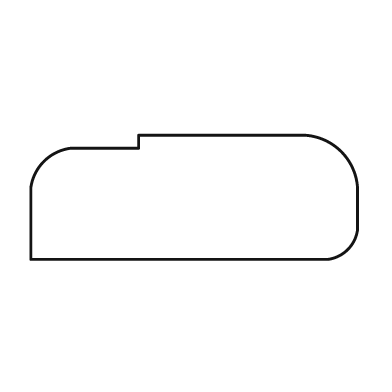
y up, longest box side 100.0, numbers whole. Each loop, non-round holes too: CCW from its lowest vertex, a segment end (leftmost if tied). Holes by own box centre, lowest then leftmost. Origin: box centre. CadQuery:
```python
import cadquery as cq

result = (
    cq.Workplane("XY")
    .moveTo(-50.0, -19.0)
    .lineTo(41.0, -19.0)
    .threePointArc((47.0, -16.0), (50.0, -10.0))
    .lineTo(50.0, 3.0)
    .threePointArc((45.0, 14.0), (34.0, 19.0))
    .lineTo(-17.0, 19.0)
    .lineTo(-17.0, 15.0)
    .lineTo(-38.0, 15.0)
    .threePointArc((-46.0, 11.0), (-50.0, 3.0))
    .close()
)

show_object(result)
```